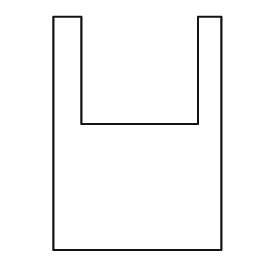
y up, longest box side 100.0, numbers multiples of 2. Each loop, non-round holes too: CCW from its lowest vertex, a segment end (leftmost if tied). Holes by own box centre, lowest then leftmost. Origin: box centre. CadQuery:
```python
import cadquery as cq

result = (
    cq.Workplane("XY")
    .moveTo(-36.0, -50.0)
    .lineTo(36.0, -50.0)
    .lineTo(36.0, 50.0)
    .lineTo(26.0, 50.0)
    .lineTo(26.0, 4.0)
    .lineTo(-24.0, 4.0)
    .lineTo(-24.0, 50.0)
    .lineTo(-36.0, 50.0)
    .close()
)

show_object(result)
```